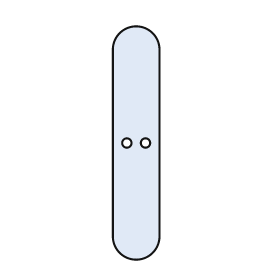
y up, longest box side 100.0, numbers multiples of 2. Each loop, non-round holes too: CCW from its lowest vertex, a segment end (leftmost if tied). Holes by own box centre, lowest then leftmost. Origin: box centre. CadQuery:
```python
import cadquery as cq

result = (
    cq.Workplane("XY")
    .moveTo(-10.0, -40.0)
    .threePointArc((0.0, -50.0), (10.0, -40.0))
    .lineTo(10.0, 40.0)
    .threePointArc((0.0, 50.0), (-10.0, 40.0))
    .close()
    .moveTo(-4.0, 0.0)
    .circle(2.0)
    .moveTo(4.0, 0.0)
    .circle(2.0)
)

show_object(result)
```